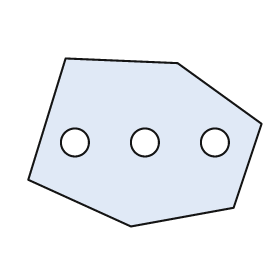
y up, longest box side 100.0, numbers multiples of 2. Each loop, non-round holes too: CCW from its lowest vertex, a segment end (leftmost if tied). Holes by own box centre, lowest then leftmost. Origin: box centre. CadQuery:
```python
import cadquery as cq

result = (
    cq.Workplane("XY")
    .moveTo(-6.0, -36.0)
    .lineTo(38.0, -28.0)
    .lineTo(50.0, 8.0)
    .lineTo(14.0, 34.0)
    .lineTo(-34.0, 36.0)
    .lineTo(-50.0, -16.0)
    .close()
    .moveTo(-30.0, 0.0)
    .circle(6.0)
    .moveTo(0.0, 0.0)
    .circle(6.0)
    .moveTo(30.0, 0.0)
    .circle(6.0)
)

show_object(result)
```